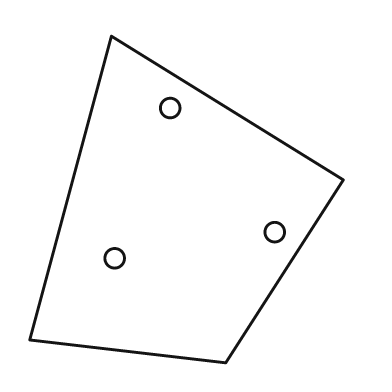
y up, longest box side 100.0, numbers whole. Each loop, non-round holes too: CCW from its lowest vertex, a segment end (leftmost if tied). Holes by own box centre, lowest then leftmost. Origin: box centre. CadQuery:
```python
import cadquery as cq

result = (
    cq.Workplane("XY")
    .moveTo(12.0, -50.0)
    .lineTo(48.0, 6.0)
    .lineTo(-23.0, 50.0)
    .lineTo(-48.0, -43.0)
    .close()
    .moveTo(-22.0, -18.0)
    .circle(3.0)
    .moveTo(27.0, -10.0)
    .circle(3.0)
    .moveTo(-5.0, 28.0)
    .circle(3.0)
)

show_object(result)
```